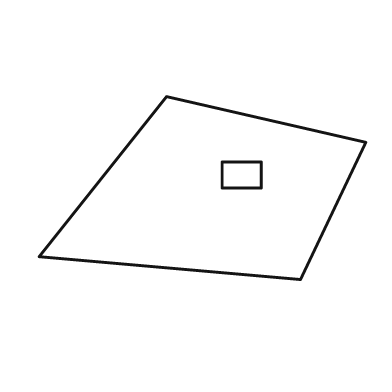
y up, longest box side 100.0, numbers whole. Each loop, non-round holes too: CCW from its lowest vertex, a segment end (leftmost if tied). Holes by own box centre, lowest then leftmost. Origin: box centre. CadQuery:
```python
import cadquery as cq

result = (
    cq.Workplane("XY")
    .moveTo(30.0, -28.0)
    .lineTo(50.0, 14.0)
    .lineTo(-11.0, 28.0)
    .lineTo(-50.0, -21.0)
    .close()
    .moveTo(6.0, 0.0)
    .lineTo(18.0, 0.0)
    .lineTo(18.0, 8.0)
    .lineTo(6.0, 8.0)
    .close()
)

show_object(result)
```